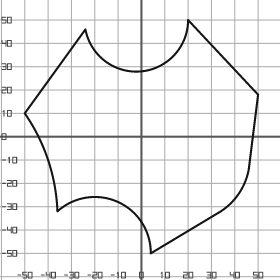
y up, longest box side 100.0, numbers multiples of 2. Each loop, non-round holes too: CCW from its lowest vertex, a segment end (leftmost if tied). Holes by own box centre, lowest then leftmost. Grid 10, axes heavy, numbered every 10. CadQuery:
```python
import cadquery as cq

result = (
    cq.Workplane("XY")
    .moveTo(4.0, -50.0)
    .lineTo(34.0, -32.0)
    .threePointArc((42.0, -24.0), (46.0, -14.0))
    .lineTo(50.0, 18.0)
    .lineTo(20.0, 50.0)
    .threePointArc((0.0, 28.0), (-24.0, 46.0))
    .lineTo(-50.0, 10.0)
    .threePointArc((-40.0, -10.0), (-36.0, -32.0))
    .threePointArc((-10.0, -28.0), (4.0, -50.0))
    .close()
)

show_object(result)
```